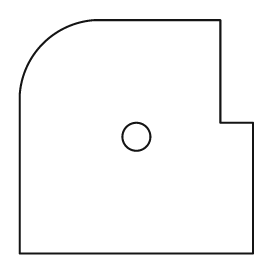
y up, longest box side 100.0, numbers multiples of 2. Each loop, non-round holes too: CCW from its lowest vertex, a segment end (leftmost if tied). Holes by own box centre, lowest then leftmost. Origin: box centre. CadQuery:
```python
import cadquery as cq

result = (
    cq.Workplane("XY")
    .moveTo(-50.0, -50.0)
    .lineTo(50.0, -50.0)
    .lineTo(50.0, 6.0)
    .lineTo(36.0, 6.0)
    .lineTo(36.0, 50.0)
    .lineTo(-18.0, 50.0)
    .threePointArc((-40.0, 40.0), (-50.0, 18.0))
    .close()
    .moveTo(0.0, 0.0)
    .circle(6.0)
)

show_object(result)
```